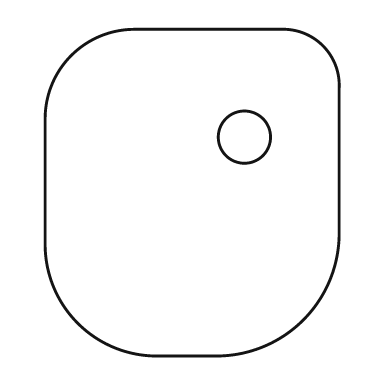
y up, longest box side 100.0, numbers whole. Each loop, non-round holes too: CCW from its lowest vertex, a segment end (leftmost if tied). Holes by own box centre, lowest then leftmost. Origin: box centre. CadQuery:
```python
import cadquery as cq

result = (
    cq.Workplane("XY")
    .moveTo(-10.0, -50.0)
    .lineTo(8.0, -50.0)
    .threePointArc((34.0, -39.0), (45.0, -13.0))
    .lineTo(45.0, 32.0)
    .threePointArc((40.0, 45.0), (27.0, 50.0))
    .lineTo(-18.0, 50.0)
    .threePointArc((-37.0, 42.0), (-45.0, 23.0))
    .lineTo(-45.0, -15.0)
    .threePointArc((-35.0, -40.0), (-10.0, -50.0))
    .close()
    .moveTo(16.0, 17.0)
    .circle(8.0)
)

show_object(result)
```